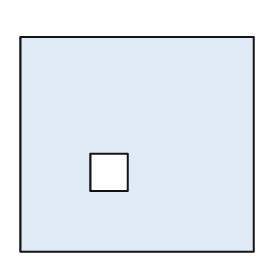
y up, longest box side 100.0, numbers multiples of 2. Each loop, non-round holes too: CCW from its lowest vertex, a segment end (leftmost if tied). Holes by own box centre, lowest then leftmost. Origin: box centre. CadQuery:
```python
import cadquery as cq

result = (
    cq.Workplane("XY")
    .moveTo(-50.0, -46.0)
    .lineTo(50.0, -46.0)
    .lineTo(50.0, 46.0)
    .lineTo(-50.0, 46.0)
    .close()
    .moveTo(-20.0, -20.0)
    .lineTo(-4.0, -20.0)
    .lineTo(-4.0, -4.0)
    .lineTo(-20.0, -4.0)
    .close()
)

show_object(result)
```